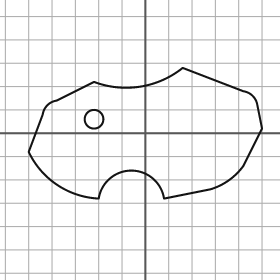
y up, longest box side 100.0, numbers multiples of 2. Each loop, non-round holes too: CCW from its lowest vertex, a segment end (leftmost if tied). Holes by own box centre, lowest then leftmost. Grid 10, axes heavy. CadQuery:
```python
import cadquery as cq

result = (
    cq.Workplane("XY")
    .moveTo(-20.0, -28.0)
    .threePointArc((-6.0, -16.0), (8.0, -28.0))
    .lineTo(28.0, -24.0)
    .threePointArc((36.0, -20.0), (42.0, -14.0))
    .lineTo(50.0, 2.0)
    .lineTo(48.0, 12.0)
    .threePointArc((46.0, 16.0), (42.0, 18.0))
    .lineTo(16.0, 28.0)
    .threePointArc((-2.0, 20.0), (-22.0, 22.0))
    .lineTo(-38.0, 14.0)
    .threePointArc((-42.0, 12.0), (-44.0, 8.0))
    .lineTo(-50.0, -8.0)
    .threePointArc((-38.0, -22.0), (-20.0, -28.0))
    .close()
    .moveTo(-22.0, 6.0)
    .circle(4.0)
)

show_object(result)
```